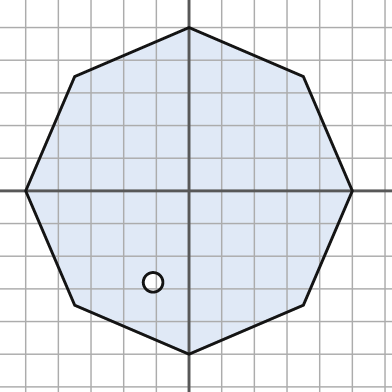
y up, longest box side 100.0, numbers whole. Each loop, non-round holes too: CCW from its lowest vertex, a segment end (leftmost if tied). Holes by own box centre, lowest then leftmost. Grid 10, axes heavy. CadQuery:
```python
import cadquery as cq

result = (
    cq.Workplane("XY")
    .moveTo(0.0, -50.0)
    .lineTo(35.0, -35.0)
    .lineTo(50.0, 0.0)
    .lineTo(35.0, 35.0)
    .lineTo(0.0, 50.0)
    .lineTo(-35.0, 35.0)
    .lineTo(-50.0, 0.0)
    .lineTo(-35.0, -35.0)
    .close()
    .moveTo(-11.0, -28.0)
    .circle(3.0)
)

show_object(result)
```